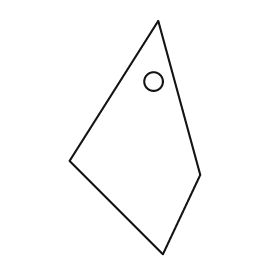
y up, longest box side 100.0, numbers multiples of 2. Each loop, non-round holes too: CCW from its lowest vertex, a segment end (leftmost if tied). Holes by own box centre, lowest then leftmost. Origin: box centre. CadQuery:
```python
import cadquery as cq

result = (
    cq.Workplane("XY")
    .moveTo(12.0, -50.0)
    .lineTo(28.0, -16.0)
    .lineTo(10.0, 50.0)
    .lineTo(-28.0, -10.0)
    .close()
    .moveTo(8.0, 24.0)
    .circle(4.0)
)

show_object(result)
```